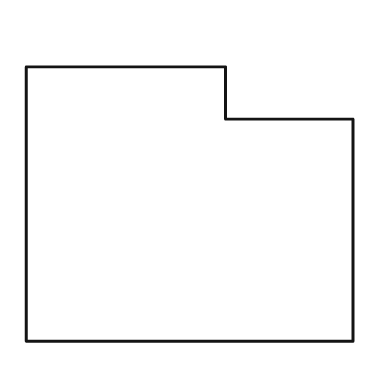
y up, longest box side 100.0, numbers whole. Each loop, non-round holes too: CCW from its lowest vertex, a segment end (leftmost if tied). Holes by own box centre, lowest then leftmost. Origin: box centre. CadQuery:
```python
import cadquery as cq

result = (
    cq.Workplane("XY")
    .moveTo(-50.0, -42.0)
    .lineTo(50.0, -42.0)
    .lineTo(50.0, 26.0)
    .lineTo(11.0, 26.0)
    .lineTo(11.0, 42.0)
    .lineTo(-50.0, 42.0)
    .close()
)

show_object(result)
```